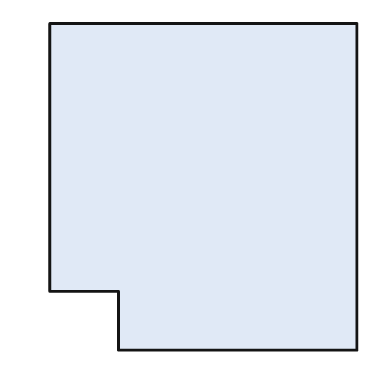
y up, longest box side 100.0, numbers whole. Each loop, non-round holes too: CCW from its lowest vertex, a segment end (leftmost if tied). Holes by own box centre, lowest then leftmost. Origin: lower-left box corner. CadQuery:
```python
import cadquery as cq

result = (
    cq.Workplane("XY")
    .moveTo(21.0, 0.0)
    .lineTo(94.0, 0.0)
    .lineTo(94.0, 100.0)
    .lineTo(0.0, 100.0)
    .lineTo(0.0, 18.0)
    .lineTo(21.0, 18.0)
    .close()
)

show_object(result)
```